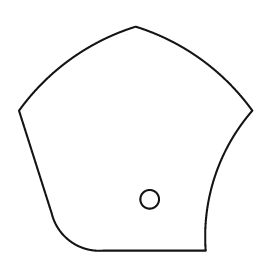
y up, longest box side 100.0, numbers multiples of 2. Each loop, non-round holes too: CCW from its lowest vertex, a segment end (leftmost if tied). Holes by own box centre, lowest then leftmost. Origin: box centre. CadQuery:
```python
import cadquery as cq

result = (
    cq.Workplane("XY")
    .moveTo(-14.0, -48.0)
    .lineTo(30.0, -48.0)
    .threePointArc((34.0, -16.0), (50.0, 12.0))
    .threePointArc((28.0, 34.0), (0.0, 48.0))
    .threePointArc((-28.0, 34.0), (-50.0, 12.0))
    .lineTo(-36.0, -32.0)
    .threePointArc((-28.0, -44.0), (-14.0, -48.0))
    .close()
    .moveTo(6.0, -26.0)
    .circle(4.0)
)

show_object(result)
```